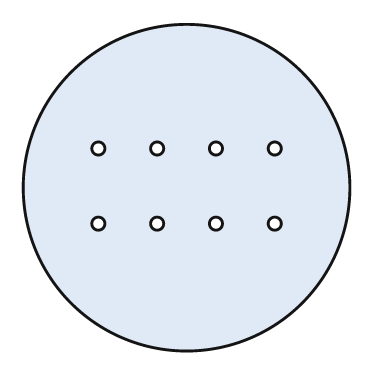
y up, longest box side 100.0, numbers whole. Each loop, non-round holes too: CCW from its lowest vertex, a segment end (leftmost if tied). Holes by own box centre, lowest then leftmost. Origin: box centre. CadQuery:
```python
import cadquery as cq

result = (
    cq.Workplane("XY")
    .moveTo(0.0, 0.0)
    .circle(50.0)
    .moveTo(-27.0, -11.0)
    .circle(2.0)
    .moveTo(-9.0, -11.0)
    .circle(2.0)
    .moveTo(9.0, -11.0)
    .circle(2.0)
    .moveTo(27.0, -11.0)
    .circle(2.0)
    .moveTo(-27.0, 12.0)
    .circle(2.0)
    .moveTo(-9.0, 12.0)
    .circle(2.0)
    .moveTo(9.0, 12.0)
    .circle(2.0)
    .moveTo(27.0, 12.0)
    .circle(2.0)
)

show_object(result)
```